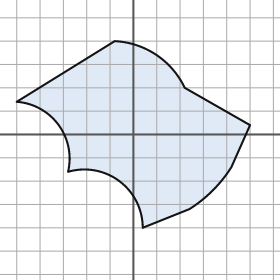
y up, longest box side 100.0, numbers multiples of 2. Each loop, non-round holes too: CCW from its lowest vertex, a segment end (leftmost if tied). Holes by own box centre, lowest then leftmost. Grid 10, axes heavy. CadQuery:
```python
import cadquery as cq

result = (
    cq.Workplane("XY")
    .moveTo(4.0, -40.0)
    .lineTo(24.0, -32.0)
    .threePointArc((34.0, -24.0), (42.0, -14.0))
    .lineTo(50.0, 4.0)
    .lineTo(22.0, 20.0)
    .threePointArc((10.0, 34.0), (-8.0, 40.0))
    .lineTo(-50.0, 14.0)
    .threePointArc((-32.0, 4.0), (-28.0, -16.0))
    .threePointArc((-6.0, -20.0), (4.0, -40.0))
    .close()
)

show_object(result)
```